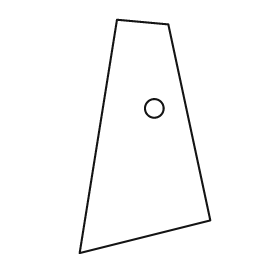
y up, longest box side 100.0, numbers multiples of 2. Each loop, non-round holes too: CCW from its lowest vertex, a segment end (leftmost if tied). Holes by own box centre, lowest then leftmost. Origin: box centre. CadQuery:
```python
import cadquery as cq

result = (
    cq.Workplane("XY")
    .moveTo(-28.0, -50.0)
    .lineTo(28.0, -36.0)
    .lineTo(10.0, 48.0)
    .lineTo(-12.0, 50.0)
    .close()
    .moveTo(4.0, 12.0)
    .circle(4.0)
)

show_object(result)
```